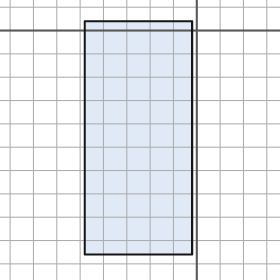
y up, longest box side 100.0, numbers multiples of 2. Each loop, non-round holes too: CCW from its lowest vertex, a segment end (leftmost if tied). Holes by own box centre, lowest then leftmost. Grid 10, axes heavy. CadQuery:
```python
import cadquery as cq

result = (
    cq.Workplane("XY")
    .moveTo(-48.0, -96.0)
    .lineTo(-2.0, -96.0)
    .lineTo(-2.0, 4.0)
    .lineTo(-48.0, 4.0)
    .close()
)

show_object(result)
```